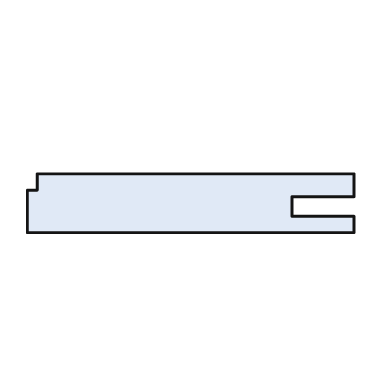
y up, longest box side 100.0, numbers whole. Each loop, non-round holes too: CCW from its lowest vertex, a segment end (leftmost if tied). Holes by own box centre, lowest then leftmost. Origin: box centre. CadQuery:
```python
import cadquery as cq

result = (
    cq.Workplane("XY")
    .moveTo(-50.0, -9.0)
    .lineTo(50.0, -9.0)
    .lineTo(50.0, -4.0)
    .lineTo(31.0, -4.0)
    .lineTo(31.0, 2.0)
    .lineTo(50.0, 2.0)
    .lineTo(50.0, 9.0)
    .lineTo(-47.0, 9.0)
    .lineTo(-47.0, 4.0)
    .lineTo(-50.0, 4.0)
    .close()
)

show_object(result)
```